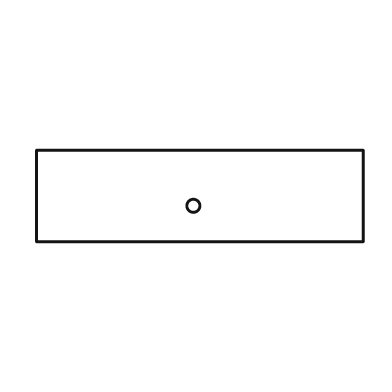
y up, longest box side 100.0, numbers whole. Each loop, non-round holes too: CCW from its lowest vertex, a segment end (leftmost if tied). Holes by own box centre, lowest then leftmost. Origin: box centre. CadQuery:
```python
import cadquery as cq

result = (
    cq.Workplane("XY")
    .moveTo(-50.0, -14.0)
    .lineTo(50.0, -14.0)
    .lineTo(50.0, 14.0)
    .lineTo(-50.0, 14.0)
    .close()
    .moveTo(-2.0, -3.0)
    .circle(2.0)
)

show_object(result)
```